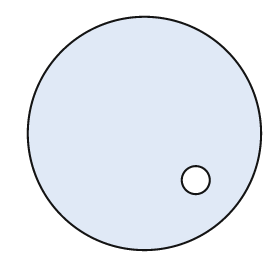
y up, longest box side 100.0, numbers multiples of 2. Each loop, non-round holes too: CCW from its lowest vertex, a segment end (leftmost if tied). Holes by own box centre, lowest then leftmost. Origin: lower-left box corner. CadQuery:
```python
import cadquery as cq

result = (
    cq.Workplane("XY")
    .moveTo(50.0, 50.0)
    .circle(50.0)
    .moveTo(72.0, 30.0)
    .circle(6.0)
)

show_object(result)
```